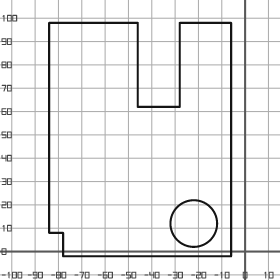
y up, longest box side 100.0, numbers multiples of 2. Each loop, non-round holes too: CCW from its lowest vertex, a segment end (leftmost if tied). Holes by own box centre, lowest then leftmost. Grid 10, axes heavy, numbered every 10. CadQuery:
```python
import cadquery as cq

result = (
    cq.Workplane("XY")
    .moveTo(-78.0, -2.0)
    .lineTo(-6.0, -2.0)
    .lineTo(-6.0, 98.0)
    .lineTo(-28.0, 98.0)
    .lineTo(-28.0, 62.0)
    .lineTo(-46.0, 62.0)
    .lineTo(-46.0, 98.0)
    .lineTo(-84.0, 98.0)
    .lineTo(-84.0, 8.0)
    .lineTo(-78.0, 8.0)
    .close()
    .moveTo(-22.0, 12.0)
    .circle(10.0)
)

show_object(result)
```